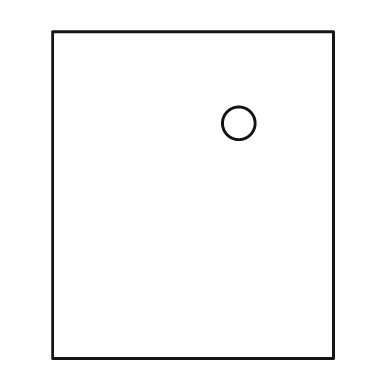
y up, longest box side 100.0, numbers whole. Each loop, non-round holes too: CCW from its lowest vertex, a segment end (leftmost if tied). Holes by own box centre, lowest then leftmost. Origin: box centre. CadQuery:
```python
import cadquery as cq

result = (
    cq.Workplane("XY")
    .moveTo(-43.0, -50.0)
    .lineTo(43.0, -50.0)
    .lineTo(43.0, 50.0)
    .lineTo(-43.0, 50.0)
    .close()
    .moveTo(14.0, 22.0)
    .circle(5.0)
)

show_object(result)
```